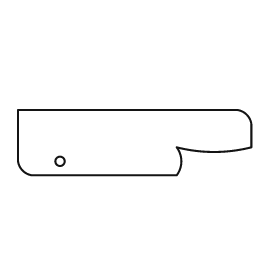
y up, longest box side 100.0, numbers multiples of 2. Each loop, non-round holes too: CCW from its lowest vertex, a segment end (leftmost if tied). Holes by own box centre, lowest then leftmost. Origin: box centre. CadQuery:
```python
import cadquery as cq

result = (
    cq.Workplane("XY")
    .moveTo(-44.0, -14.0)
    .lineTo(18.0, -14.0)
    .threePointArc((20.0, -8.0), (18.0, -2.0))
    .threePointArc((34.0, -4.0), (50.0, -2.0))
    .lineTo(50.0, 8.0)
    .threePointArc((48.0, 12.0), (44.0, 14.0))
    .lineTo(-50.0, 14.0)
    .lineTo(-50.0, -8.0)
    .threePointArc((-48.0, -12.0), (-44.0, -14.0))
    .close()
    .moveTo(-32.0, -8.0)
    .circle(2.0)
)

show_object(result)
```